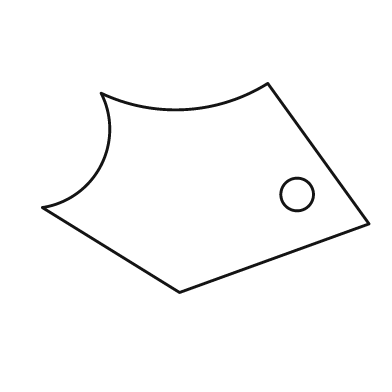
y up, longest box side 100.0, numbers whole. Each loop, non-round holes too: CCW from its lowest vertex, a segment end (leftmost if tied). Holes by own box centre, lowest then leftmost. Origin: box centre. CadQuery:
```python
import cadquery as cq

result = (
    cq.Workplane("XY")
    .moveTo(-8.0, -32.0)
    .lineTo(50.0, -11.0)
    .lineTo(19.0, 32.0)
    .threePointArc((-6.0, 24.0), (-32.0, 29.0))
    .threePointArc((-32.0, 7.0), (-50.0, -6.0))
    .close()
    .moveTo(28.0, -2.0)
    .circle(5.0)
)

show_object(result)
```